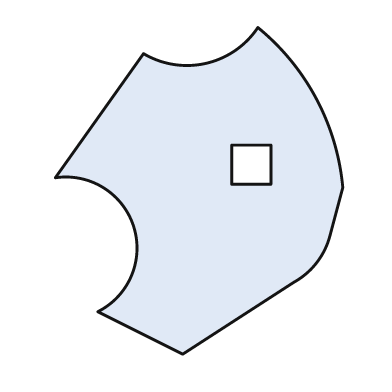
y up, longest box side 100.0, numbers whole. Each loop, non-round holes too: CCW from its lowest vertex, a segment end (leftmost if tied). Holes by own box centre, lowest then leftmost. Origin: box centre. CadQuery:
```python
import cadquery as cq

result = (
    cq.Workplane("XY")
    .moveTo(-5.0, -50.0)
    .lineTo(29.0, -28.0)
    .threePointArc((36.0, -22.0), (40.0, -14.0))
    .lineTo(44.0, 1.0)
    .threePointArc((36.0, 28.0), (18.0, 50.0))
    .threePointArc((2.0, 39.0), (-17.0, 42.0))
    .lineTo(-44.0, 4.0)
    .threePointArc((-20.0, -11.0), (-31.0, -37.0))
    .close()
    .moveTo(10.0, 2.0)
    .lineTo(22.0, 2.0)
    .lineTo(22.0, 14.0)
    .lineTo(10.0, 14.0)
    .close()
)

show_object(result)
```